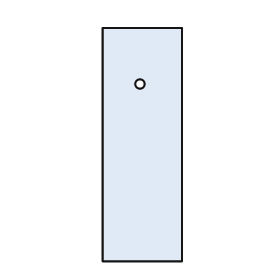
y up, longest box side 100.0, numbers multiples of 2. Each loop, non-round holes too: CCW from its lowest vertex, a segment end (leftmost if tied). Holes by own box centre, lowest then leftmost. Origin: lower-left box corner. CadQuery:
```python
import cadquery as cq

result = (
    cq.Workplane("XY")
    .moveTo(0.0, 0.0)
    .lineTo(34.0, 0.0)
    .lineTo(34.0, 100.0)
    .lineTo(0.0, 100.0)
    .close()
    .moveTo(16.0, 76.0)
    .circle(2.0)
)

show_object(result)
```